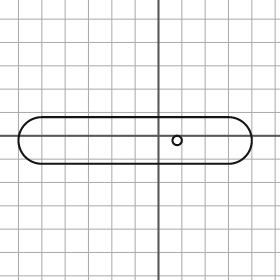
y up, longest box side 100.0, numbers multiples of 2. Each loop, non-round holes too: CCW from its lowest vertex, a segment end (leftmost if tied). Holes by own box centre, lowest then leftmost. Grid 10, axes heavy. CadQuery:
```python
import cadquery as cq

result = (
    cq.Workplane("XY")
    .moveTo(-50.0, -12.0)
    .lineTo(30.0, -12.0)
    .threePointArc((40.0, -2.0), (30.0, 8.0))
    .lineTo(-50.0, 8.0)
    .threePointArc((-60.0, -2.0), (-50.0, -12.0))
    .close()
    .moveTo(8.0, -2.0)
    .circle(2.0)
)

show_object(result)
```